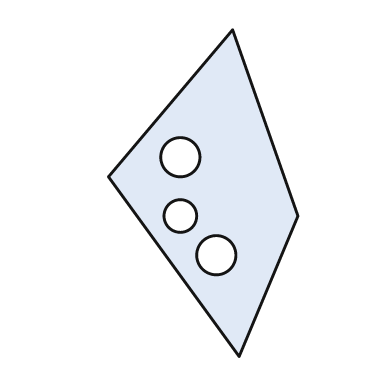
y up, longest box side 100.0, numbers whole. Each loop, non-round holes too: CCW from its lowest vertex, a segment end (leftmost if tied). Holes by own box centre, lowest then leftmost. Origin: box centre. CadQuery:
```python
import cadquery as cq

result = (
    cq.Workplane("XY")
    .moveTo(11.0, -50.0)
    .lineTo(29.0, -7.0)
    .lineTo(9.0, 50.0)
    .lineTo(-29.0, 5.0)
    .close()
    .moveTo(4.0, -19.0)
    .circle(6.0)
    .moveTo(-7.0, -7.0)
    .circle(5.0)
    .moveTo(-7.0, 11.0)
    .circle(6.0)
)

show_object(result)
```